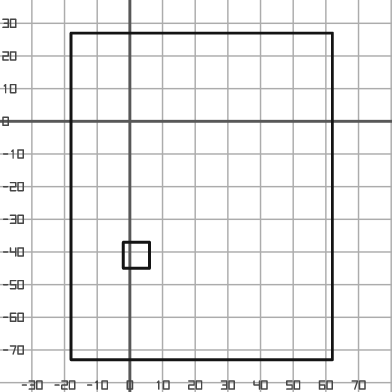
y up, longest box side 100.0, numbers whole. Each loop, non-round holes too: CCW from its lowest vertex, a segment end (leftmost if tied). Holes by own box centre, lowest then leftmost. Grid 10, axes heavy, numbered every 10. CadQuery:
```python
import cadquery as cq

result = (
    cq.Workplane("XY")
    .moveTo(-18.0, -73.0)
    .lineTo(62.0, -73.0)
    .lineTo(62.0, 27.0)
    .lineTo(-18.0, 27.0)
    .close()
    .moveTo(-2.0, -45.0)
    .lineTo(6.0, -45.0)
    .lineTo(6.0, -37.0)
    .lineTo(-2.0, -37.0)
    .close()
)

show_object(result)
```